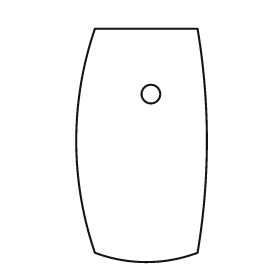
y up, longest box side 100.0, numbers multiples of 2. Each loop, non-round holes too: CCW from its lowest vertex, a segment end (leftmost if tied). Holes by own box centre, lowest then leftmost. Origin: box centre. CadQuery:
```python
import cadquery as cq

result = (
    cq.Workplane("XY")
    .moveTo(-20.0, -46.0)
    .threePointArc((2.0, -50.0), (24.0, -46.0))
    .threePointArc((28.0, 2.0), (24.0, 50.0))
    .lineTo(-20.0, 50.0)
    .threePointArc((-28.0, 2.0), (-20.0, -46.0))
    .close()
    .moveTo(4.0, 22.0)
    .circle(4.0)
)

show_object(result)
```